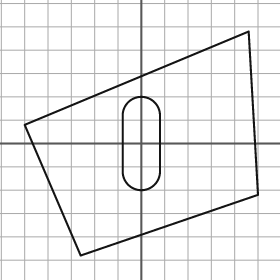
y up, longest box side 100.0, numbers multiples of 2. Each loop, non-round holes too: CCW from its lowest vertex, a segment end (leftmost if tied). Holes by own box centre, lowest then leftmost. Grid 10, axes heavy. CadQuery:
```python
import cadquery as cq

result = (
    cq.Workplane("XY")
    .moveTo(-26.0, -48.0)
    .lineTo(50.0, -22.0)
    .lineTo(46.0, 48.0)
    .lineTo(-50.0, 8.0)
    .close()
    .moveTo(-8.0, -12.0)
    .threePointArc((0.0, -20.0), (8.0, -12.0))
    .lineTo(8.0, 12.0)
    .threePointArc((0.0, 20.0), (-8.0, 12.0))
    .close()
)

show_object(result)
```